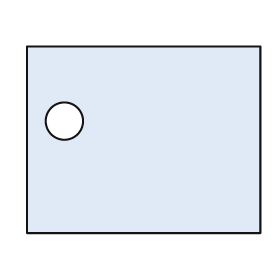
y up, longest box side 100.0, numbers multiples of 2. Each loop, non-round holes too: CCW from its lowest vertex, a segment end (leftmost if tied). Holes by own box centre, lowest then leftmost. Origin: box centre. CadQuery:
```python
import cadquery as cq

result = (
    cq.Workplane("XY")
    .moveTo(-50.0, -40.0)
    .lineTo(50.0, -40.0)
    .lineTo(50.0, 40.0)
    .lineTo(-50.0, 40.0)
    .close()
    .moveTo(-34.0, 8.0)
    .circle(8.0)
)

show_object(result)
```